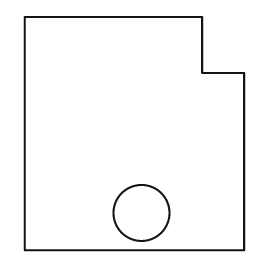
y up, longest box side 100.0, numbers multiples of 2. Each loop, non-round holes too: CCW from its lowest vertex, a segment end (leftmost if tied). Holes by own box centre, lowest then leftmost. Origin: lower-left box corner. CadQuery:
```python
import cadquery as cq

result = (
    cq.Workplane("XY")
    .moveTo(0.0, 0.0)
    .lineTo(94.0, 0.0)
    .lineTo(94.0, 76.0)
    .lineTo(76.0, 76.0)
    .lineTo(76.0, 100.0)
    .lineTo(0.0, 100.0)
    .close()
    .moveTo(50.0, 16.0)
    .circle(12.0)
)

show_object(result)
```